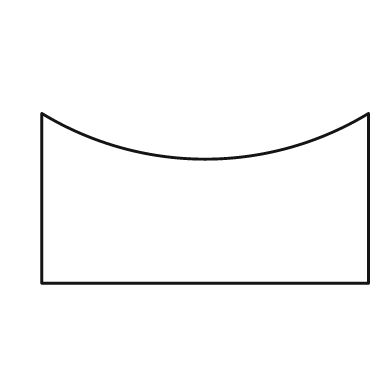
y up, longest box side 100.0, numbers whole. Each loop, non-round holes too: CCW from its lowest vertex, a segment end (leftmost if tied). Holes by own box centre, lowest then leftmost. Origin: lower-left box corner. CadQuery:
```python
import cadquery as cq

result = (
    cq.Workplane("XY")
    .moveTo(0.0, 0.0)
    .lineTo(100.0, 0.0)
    .lineTo(100.0, 52.0)
    .threePointArc((50.0, 38.0), (0.0, 52.0))
    .close()
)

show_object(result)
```